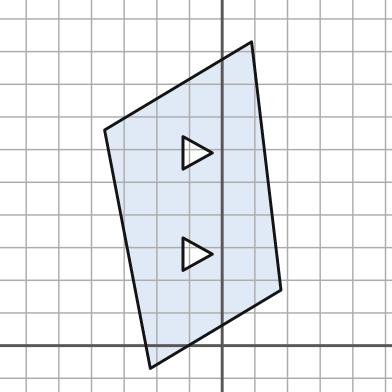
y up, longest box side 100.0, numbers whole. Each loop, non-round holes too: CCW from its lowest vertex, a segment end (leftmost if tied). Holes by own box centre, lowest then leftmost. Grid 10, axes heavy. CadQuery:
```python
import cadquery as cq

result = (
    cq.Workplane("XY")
    .moveTo(-22.0, -7.0)
    .lineTo(18.0, 17.0)
    .lineTo(9.0, 93.0)
    .lineTo(-36.0, 66.0)
    .close()
    .moveTo(-12.0, 23.0)
    .lineTo(-3.0, 28.0)
    .lineTo(-12.0, 33.0)
    .close()
    .moveTo(-12.0, 54.0)
    .lineTo(-3.0, 59.0)
    .lineTo(-12.0, 64.0)
    .close()
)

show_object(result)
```